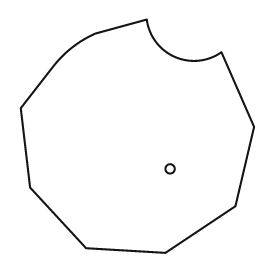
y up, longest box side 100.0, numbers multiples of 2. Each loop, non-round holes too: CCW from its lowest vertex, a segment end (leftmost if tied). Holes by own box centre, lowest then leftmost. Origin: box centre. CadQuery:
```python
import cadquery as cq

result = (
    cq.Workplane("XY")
    .moveTo(12.0, -50.0)
    .lineTo(42.0, -30.0)
    .lineTo(50.0, 4.0)
    .lineTo(36.0, 36.0)
    .threePointArc((16.0, 34.0), (4.0, 50.0))
    .lineTo(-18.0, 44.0)
    .threePointArc((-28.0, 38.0), (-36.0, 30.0))
    .lineTo(-50.0, 12.0)
    .lineTo(-46.0, -22.0)
    .lineTo(-22.0, -48.0)
    .close()
    .moveTo(14.0, -14.0)
    .circle(2.0)
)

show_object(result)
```